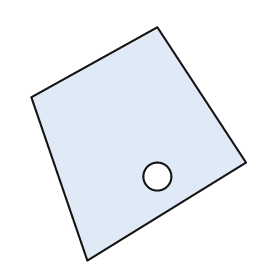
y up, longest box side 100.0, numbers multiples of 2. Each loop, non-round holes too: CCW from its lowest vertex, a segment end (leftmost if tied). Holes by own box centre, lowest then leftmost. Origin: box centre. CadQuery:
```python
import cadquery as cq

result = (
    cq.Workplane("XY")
    .moveTo(-22.0, -50.0)
    .lineTo(46.0, -8.0)
    .lineTo(8.0, 50.0)
    .lineTo(-46.0, 20.0)
    .close()
    .moveTo(8.0, -14.0)
    .circle(6.0)
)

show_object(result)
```